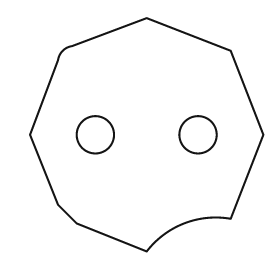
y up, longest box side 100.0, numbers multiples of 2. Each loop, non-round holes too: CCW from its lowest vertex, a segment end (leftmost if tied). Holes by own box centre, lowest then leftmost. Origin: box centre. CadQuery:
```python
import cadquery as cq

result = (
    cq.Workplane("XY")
    .moveTo(0.0, -50.0)
    .threePointArc((16.0, -38.0), (36.0, -36.0))
    .lineTo(50.0, 0.0)
    .lineTo(36.0, 36.0)
    .lineTo(0.0, 50.0)
    .lineTo(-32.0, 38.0)
    .threePointArc((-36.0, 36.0), (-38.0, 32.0))
    .lineTo(-50.0, 0.0)
    .lineTo(-38.0, -30.0)
    .lineTo(-30.0, -38.0)
    .close()
    .moveTo(-22.0, 0.0)
    .circle(8.0)
    .moveTo(22.0, 0.0)
    .circle(8.0)
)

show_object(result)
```